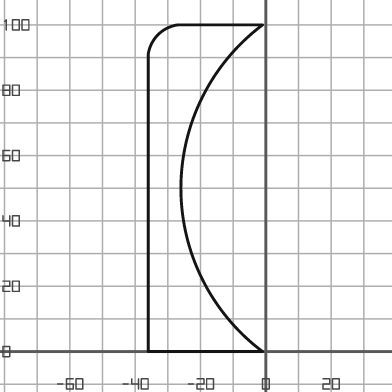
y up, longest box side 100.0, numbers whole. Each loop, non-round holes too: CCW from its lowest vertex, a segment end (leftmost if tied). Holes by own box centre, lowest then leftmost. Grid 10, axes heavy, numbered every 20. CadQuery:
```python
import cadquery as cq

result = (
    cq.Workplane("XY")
    .moveTo(-36.0, 0.0)
    .lineTo(-1.0, 0.0)
    .threePointArc((-26.0, 50.0), (-1.0, 100.0))
    .lineTo(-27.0, 100.0)
    .threePointArc((-33.0, 97.0), (-36.0, 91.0))
    .close()
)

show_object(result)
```